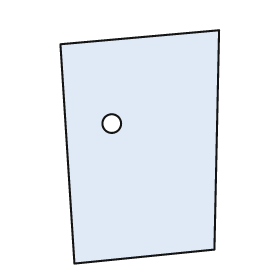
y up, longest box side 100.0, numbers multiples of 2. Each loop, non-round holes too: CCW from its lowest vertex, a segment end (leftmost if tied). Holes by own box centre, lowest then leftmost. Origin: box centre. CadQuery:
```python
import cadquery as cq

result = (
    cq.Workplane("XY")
    .moveTo(-28.0, -50.0)
    .lineTo(32.0, -44.0)
    .lineTo(34.0, 50.0)
    .lineTo(-34.0, 44.0)
    .close()
    .moveTo(-12.0, 10.0)
    .circle(4.0)
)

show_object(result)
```